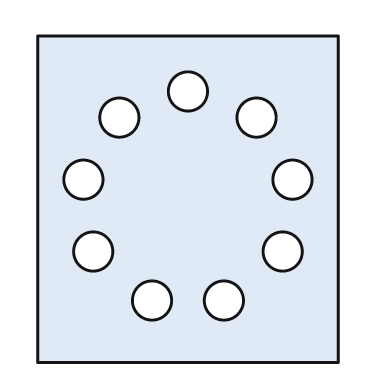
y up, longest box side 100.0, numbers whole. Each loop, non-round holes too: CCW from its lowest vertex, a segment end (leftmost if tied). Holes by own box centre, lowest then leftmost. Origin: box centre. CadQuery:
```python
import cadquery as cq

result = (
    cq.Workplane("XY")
    .moveTo(-46.0, -50.0)
    .lineTo(46.0, -50.0)
    .lineTo(46.0, 50.0)
    .lineTo(-46.0, 50.0)
    .close()
    .moveTo(-11.0, -31.0)
    .circle(6.0)
    .moveTo(11.0, -31.0)
    .circle(6.0)
    .moveTo(-29.0, -16.0)
    .circle(6.0)
    .moveTo(29.0, -16.0)
    .circle(6.0)
    .moveTo(-32.0, 6.0)
    .circle(6.0)
    .moveTo(32.0, 6.0)
    .circle(6.0)
    .moveTo(-21.0, 25.0)
    .circle(6.0)
    .moveTo(21.0, 25.0)
    .circle(6.0)
    .moveTo(0.0, 33.0)
    .circle(6.0)
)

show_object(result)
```